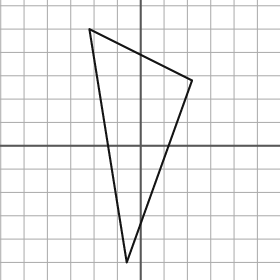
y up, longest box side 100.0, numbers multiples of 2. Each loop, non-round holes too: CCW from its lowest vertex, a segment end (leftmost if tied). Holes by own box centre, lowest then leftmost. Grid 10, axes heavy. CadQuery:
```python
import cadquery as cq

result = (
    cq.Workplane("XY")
    .moveTo(-6.0, -50.0)
    .lineTo(22.0, 28.0)
    .lineTo(-22.0, 50.0)
    .close()
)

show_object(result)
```